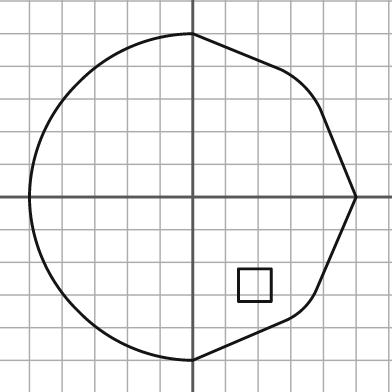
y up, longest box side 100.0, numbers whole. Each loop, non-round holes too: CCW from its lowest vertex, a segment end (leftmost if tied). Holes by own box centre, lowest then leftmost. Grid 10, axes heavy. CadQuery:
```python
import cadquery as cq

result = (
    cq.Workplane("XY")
    .moveTo(0.0, -50.0)
    .lineTo(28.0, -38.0)
    .threePointArc((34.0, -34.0), (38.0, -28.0))
    .lineTo(50.0, 0.0)
    .lineTo(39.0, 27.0)
    .threePointArc((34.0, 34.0), (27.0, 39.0))
    .lineTo(0.0, 50.0)
    .threePointArc((-19.0, 46.0), (-35.0, 35.0))
    .threePointArc((-46.0, 19.0), (-50.0, 0.0))
    .threePointArc((-46.0, -19.0), (-35.0, -35.0))
    .threePointArc((-19.0, -46.0), (0.0, -50.0))
    .close()
    .moveTo(14.0, -32.0)
    .lineTo(24.0, -32.0)
    .lineTo(24.0, -22.0)
    .lineTo(14.0, -22.0)
    .close()
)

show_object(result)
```